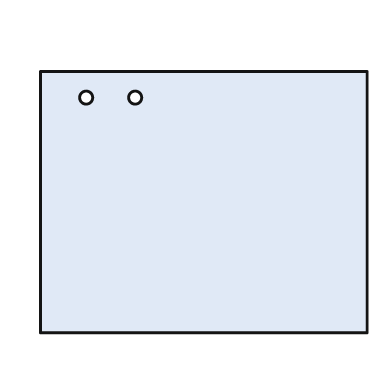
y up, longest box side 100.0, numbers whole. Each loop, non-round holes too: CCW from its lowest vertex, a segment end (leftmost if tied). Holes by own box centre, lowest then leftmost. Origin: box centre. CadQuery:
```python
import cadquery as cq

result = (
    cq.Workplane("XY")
    .moveTo(-50.0, -40.0)
    .lineTo(50.0, -40.0)
    .lineTo(50.0, 40.0)
    .lineTo(-50.0, 40.0)
    .close()
    .moveTo(-36.0, 32.0)
    .circle(2.0)
    .moveTo(-21.0, 32.0)
    .circle(2.0)
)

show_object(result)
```